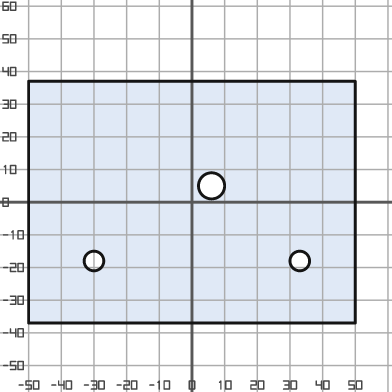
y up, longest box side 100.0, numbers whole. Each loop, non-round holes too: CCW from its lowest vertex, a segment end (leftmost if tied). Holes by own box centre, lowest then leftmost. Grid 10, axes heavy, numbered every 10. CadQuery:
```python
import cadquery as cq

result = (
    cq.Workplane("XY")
    .moveTo(-50.0, -37.0)
    .lineTo(50.0, -37.0)
    .lineTo(50.0, 37.0)
    .lineTo(-50.0, 37.0)
    .close()
    .moveTo(-30.0, -18.0)
    .circle(3.0)
    .moveTo(33.0, -18.0)
    .circle(3.0)
    .moveTo(6.0, 5.0)
    .circle(4.0)
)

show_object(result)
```